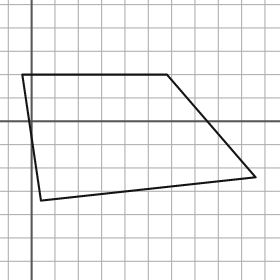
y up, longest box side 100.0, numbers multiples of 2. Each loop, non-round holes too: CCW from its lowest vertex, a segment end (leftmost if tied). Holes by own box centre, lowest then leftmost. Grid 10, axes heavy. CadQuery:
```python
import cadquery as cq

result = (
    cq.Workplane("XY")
    .moveTo(4.0, -34.0)
    .lineTo(96.0, -24.0)
    .lineTo(58.0, 20.0)
    .lineTo(-4.0, 20.0)
    .close()
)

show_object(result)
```